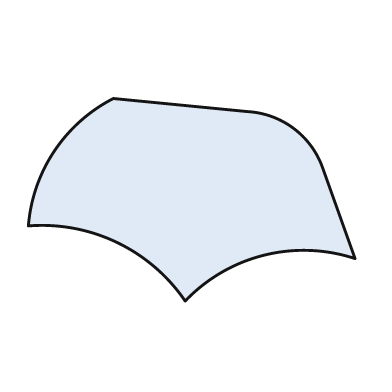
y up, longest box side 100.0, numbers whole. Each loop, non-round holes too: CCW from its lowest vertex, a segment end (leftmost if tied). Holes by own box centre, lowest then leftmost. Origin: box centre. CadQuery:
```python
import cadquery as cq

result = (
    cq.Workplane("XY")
    .moveTo(-2.0, -31.0)
    .threePointArc((22.0, -17.0), (50.0, -18.0))
    .lineTo(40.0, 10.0)
    .threePointArc((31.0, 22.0), (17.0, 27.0))
    .lineTo(-24.0, 31.0)
    .threePointArc((-42.0, 15.0), (-50.0, -8.0))
    .threePointArc((-23.0, -13.0), (-2.0, -31.0))
    .close()
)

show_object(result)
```